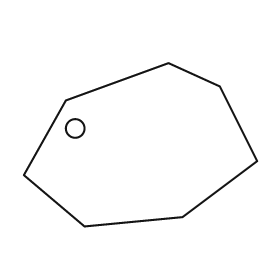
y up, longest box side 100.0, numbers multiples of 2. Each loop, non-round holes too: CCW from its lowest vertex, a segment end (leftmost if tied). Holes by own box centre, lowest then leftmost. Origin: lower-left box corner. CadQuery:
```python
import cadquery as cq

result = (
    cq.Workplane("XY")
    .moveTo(26.0, 0.0)
    .lineTo(68.0, 4.0)
    .lineTo(100.0, 28.0)
    .lineTo(84.0, 60.0)
    .lineTo(62.0, 70.0)
    .lineTo(18.0, 54.0)
    .lineTo(0.0, 22.0)
    .close()
    .moveTo(22.0, 42.0)
    .circle(4.0)
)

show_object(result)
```